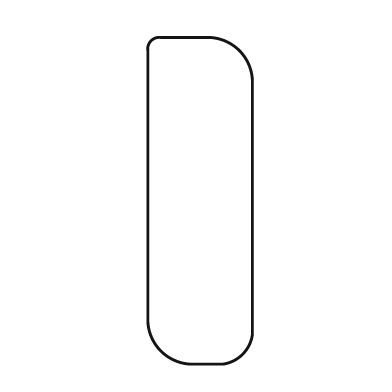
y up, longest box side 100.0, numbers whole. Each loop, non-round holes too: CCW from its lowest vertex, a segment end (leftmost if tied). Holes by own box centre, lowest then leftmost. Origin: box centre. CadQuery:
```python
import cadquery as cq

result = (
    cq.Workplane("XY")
    .moveTo(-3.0, -50.0)
    .lineTo(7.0, -50.0)
    .threePointArc((13.0, -47.0), (16.0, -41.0))
    .lineTo(16.0, 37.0)
    .threePointArc((12.0, 46.0), (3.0, 50.0))
    .lineTo(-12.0, 50.0)
    .threePointArc((-15.0, 49.0), (-16.0, 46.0))
    .lineTo(-16.0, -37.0)
    .threePointArc((-12.0, -46.0), (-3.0, -50.0))
    .close()
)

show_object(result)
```